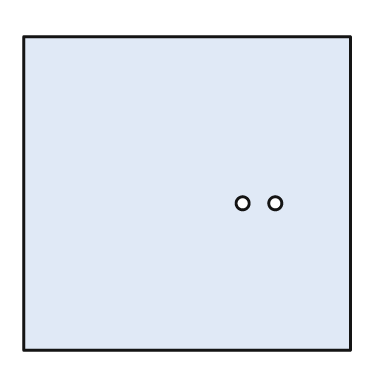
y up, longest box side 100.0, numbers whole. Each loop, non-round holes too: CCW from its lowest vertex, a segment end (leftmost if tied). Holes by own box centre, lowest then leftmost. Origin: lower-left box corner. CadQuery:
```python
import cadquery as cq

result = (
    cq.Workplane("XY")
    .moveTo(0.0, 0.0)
    .lineTo(100.0, 0.0)
    .lineTo(100.0, 96.0)
    .lineTo(0.0, 96.0)
    .close()
    .moveTo(67.0, 45.0)
    .circle(2.0)
    .moveTo(77.0, 45.0)
    .circle(2.0)
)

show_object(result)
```